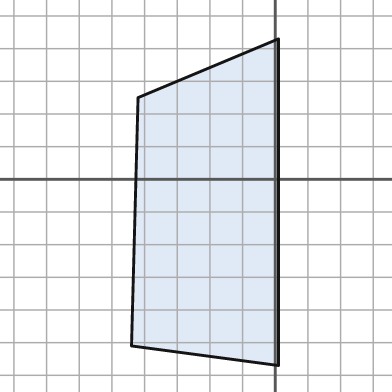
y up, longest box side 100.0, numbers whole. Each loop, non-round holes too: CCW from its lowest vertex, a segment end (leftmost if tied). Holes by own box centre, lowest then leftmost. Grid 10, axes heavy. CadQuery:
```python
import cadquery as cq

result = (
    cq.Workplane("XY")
    .moveTo(1.0, -57.0)
    .lineTo(1.0, 43.0)
    .lineTo(-42.0, 25.0)
    .lineTo(-44.0, -51.0)
    .close()
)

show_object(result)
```